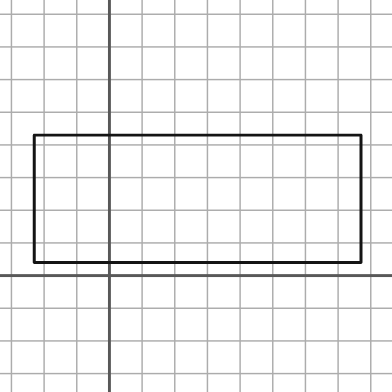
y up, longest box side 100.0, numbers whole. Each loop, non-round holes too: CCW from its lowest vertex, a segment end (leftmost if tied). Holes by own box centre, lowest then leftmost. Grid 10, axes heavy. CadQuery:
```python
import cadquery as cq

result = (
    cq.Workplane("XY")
    .moveTo(-23.0, 4.0)
    .lineTo(77.0, 4.0)
    .lineTo(77.0, 43.0)
    .lineTo(-23.0, 43.0)
    .close()
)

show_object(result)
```